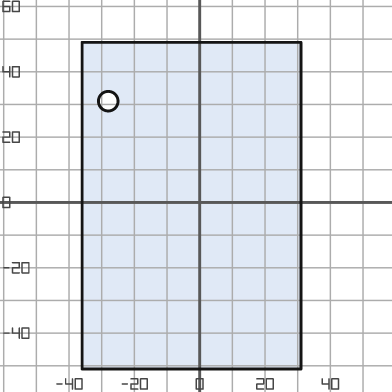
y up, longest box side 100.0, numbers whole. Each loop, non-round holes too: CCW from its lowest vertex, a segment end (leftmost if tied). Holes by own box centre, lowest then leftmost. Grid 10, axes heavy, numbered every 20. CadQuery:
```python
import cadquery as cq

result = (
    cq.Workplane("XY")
    .moveTo(-36.0, -51.0)
    .lineTo(31.0, -51.0)
    .lineTo(31.0, 49.0)
    .lineTo(-36.0, 49.0)
    .close()
    .moveTo(-28.0, 31.0)
    .circle(3.0)
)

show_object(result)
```